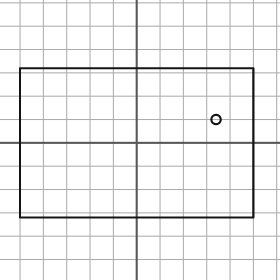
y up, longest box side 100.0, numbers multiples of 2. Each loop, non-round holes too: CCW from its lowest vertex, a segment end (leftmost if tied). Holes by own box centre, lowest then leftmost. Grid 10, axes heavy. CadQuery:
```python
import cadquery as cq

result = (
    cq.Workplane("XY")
    .moveTo(-50.0, -32.0)
    .lineTo(50.0, -32.0)
    .lineTo(50.0, 32.0)
    .lineTo(-50.0, 32.0)
    .close()
    .moveTo(34.0, 10.0)
    .circle(2.0)
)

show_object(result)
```